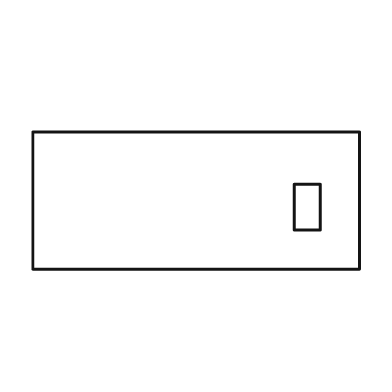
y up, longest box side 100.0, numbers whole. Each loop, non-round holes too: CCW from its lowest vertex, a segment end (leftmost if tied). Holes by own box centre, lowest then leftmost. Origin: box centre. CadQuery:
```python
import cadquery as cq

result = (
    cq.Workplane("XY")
    .moveTo(-50.0, -21.0)
    .lineTo(50.0, -21.0)
    .lineTo(50.0, 21.0)
    .lineTo(-50.0, 21.0)
    .close()
    .moveTo(30.0, -9.0)
    .lineTo(38.0, -9.0)
    .lineTo(38.0, 5.0)
    .lineTo(30.0, 5.0)
    .close()
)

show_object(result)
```